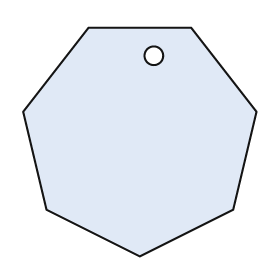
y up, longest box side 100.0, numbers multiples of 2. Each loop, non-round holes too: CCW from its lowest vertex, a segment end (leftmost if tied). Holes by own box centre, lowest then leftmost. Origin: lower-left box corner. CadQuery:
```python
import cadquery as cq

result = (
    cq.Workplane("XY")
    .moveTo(50.0, 0.0)
    .lineTo(90.0, 20.0)
    .lineTo(100.0, 62.0)
    .lineTo(72.0, 98.0)
    .lineTo(28.0, 98.0)
    .lineTo(0.0, 62.0)
    .lineTo(10.0, 20.0)
    .close()
    .moveTo(56.0, 86.0)
    .circle(4.0)
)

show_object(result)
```